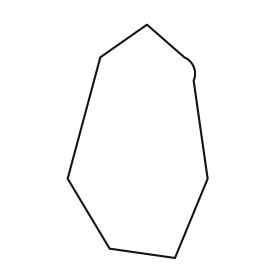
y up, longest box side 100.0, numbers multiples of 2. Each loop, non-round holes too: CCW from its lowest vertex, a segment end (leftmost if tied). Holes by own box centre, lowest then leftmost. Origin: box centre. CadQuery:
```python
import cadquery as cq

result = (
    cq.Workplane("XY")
    .moveTo(16.0, -50.0)
    .lineTo(30.0, -16.0)
    .lineTo(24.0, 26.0)
    .threePointArc((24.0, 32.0), (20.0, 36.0))
    .lineTo(4.0, 50.0)
    .lineTo(-16.0, 36.0)
    .lineTo(-30.0, -16.0)
    .lineTo(-12.0, -46.0)
    .close()
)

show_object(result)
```